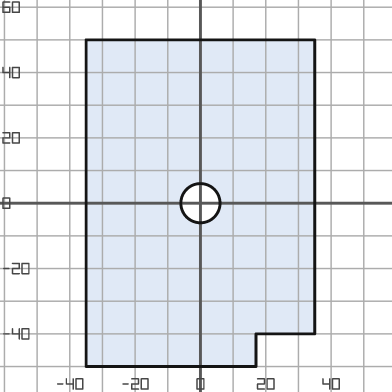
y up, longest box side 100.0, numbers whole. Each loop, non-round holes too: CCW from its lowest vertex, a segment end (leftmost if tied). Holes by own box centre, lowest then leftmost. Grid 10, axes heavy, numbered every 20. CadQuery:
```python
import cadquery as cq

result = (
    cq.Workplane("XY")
    .moveTo(-35.0, -50.0)
    .lineTo(17.0, -50.0)
    .lineTo(17.0, -40.0)
    .lineTo(35.0, -40.0)
    .lineTo(35.0, 50.0)
    .lineTo(-35.0, 50.0)
    .close()
    .moveTo(0.0, 0.0)
    .circle(6.0)
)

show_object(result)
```